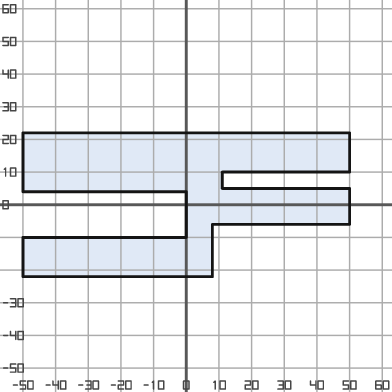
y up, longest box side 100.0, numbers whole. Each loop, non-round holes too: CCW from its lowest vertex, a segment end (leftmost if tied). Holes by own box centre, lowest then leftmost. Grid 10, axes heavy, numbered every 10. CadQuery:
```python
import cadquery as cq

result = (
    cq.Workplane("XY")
    .moveTo(-50.0, -22.0)
    .lineTo(8.0, -22.0)
    .lineTo(8.0, -6.0)
    .lineTo(50.0, -6.0)
    .lineTo(50.0, 5.0)
    .lineTo(11.0, 5.0)
    .lineTo(11.0, 10.0)
    .lineTo(50.0, 10.0)
    .lineTo(50.0, 22.0)
    .lineTo(-50.0, 22.0)
    .lineTo(-50.0, 4.0)
    .lineTo(0.0, 4.0)
    .lineTo(0.0, -10.0)
    .lineTo(-50.0, -10.0)
    .close()
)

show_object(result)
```